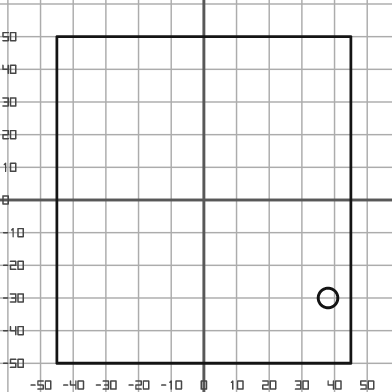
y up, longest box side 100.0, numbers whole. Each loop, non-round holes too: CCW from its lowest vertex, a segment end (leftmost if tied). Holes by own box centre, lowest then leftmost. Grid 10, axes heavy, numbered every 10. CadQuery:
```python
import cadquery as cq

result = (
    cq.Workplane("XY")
    .moveTo(-45.0, -50.0)
    .lineTo(45.0, -50.0)
    .lineTo(45.0, 50.0)
    .lineTo(-45.0, 50.0)
    .close()
    .moveTo(38.0, -30.0)
    .circle(3.0)
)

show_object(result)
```